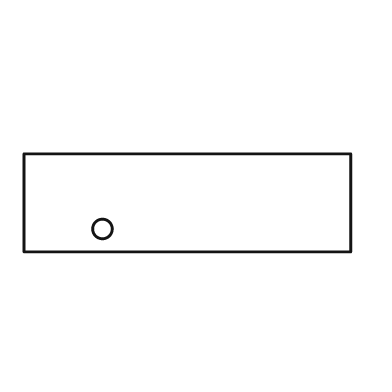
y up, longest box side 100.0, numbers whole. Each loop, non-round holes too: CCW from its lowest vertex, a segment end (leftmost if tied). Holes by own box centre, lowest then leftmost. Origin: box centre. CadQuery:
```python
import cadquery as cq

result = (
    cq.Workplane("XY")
    .moveTo(-50.0, -15.0)
    .lineTo(50.0, -15.0)
    .lineTo(50.0, 15.0)
    .lineTo(-50.0, 15.0)
    .close()
    .moveTo(-26.0, -8.0)
    .circle(3.0)
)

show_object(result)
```